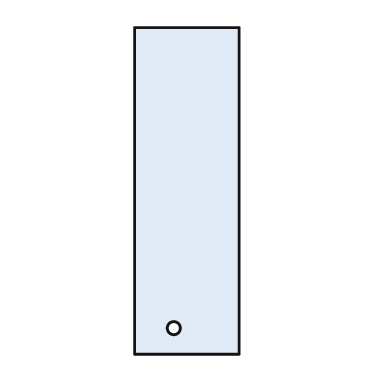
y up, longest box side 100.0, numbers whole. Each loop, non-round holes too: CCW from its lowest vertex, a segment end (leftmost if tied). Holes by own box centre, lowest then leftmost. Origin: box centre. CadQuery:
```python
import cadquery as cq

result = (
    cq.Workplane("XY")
    .moveTo(-16.0, -50.0)
    .lineTo(16.0, -50.0)
    .lineTo(16.0, 50.0)
    .lineTo(-16.0, 50.0)
    .close()
    .moveTo(-4.0, -42.0)
    .circle(2.0)
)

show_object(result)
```